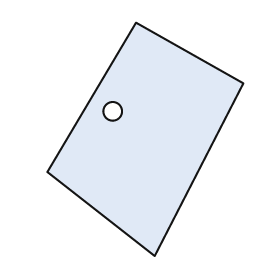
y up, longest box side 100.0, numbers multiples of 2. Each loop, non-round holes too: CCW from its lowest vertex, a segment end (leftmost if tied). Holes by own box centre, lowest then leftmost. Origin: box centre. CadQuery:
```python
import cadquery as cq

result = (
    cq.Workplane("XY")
    .moveTo(4.0, -50.0)
    .lineTo(42.0, 24.0)
    .lineTo(-4.0, 50.0)
    .lineTo(-42.0, -14.0)
    .close()
    .moveTo(-14.0, 12.0)
    .circle(4.0)
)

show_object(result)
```